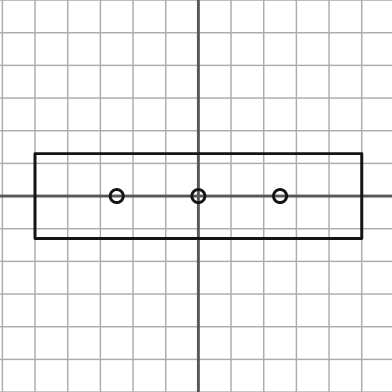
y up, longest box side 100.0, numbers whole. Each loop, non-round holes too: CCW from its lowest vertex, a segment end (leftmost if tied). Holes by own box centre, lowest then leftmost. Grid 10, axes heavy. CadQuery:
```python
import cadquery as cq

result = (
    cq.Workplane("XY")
    .moveTo(-50.0, -13.0)
    .lineTo(50.0, -13.0)
    .lineTo(50.0, 13.0)
    .lineTo(-50.0, 13.0)
    .close()
    .moveTo(-25.0, 0.0)
    .circle(2.0)
    .moveTo(0.0, 0.0)
    .circle(2.0)
    .moveTo(25.0, 0.0)
    .circle(2.0)
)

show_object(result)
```